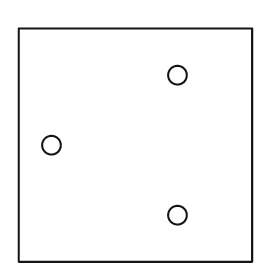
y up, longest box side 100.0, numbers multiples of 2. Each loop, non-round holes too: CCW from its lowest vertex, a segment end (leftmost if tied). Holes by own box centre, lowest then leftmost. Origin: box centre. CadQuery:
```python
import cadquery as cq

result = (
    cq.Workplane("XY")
    .moveTo(-50.0, -50.0)
    .lineTo(50.0, -50.0)
    .lineTo(50.0, 50.0)
    .lineTo(-50.0, 50.0)
    .close()
    .moveTo(18.0, -30.0)
    .circle(4.0)
    .moveTo(-36.0, 0.0)
    .circle(4.0)
    .moveTo(18.0, 30.0)
    .circle(4.0)
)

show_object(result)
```